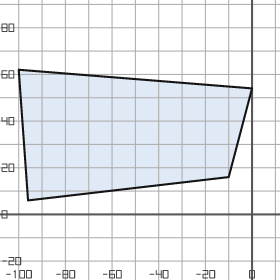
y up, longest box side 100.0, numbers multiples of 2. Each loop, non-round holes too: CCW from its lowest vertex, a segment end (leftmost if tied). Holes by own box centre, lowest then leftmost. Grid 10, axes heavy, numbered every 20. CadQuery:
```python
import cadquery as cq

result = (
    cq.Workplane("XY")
    .moveTo(-96.0, 6.0)
    .lineTo(-10.0, 16.0)
    .lineTo(0.0, 54.0)
    .lineTo(-100.0, 62.0)
    .close()
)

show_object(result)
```